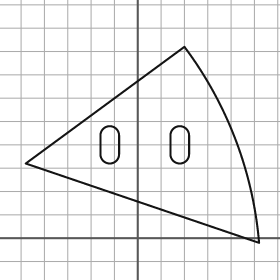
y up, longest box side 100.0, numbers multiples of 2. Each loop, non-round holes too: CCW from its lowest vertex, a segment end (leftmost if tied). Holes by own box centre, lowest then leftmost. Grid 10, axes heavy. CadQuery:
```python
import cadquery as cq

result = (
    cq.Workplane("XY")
    .moveTo(52.0, -2.0)
    .threePointArc((42.0, 42.0), (20.0, 82.0))
    .lineTo(-48.0, 32.0)
    .close()
    .moveTo(-16.0, 36.0)
    .threePointArc((-12.0, 32.0), (-8.0, 36.0))
    .lineTo(-8.0, 44.0)
    .threePointArc((-12.0, 48.0), (-16.0, 44.0))
    .close()
    .moveTo(14.0, 36.0)
    .threePointArc((18.0, 32.0), (22.0, 36.0))
    .lineTo(22.0, 44.0)
    .threePointArc((18.0, 48.0), (14.0, 44.0))
    .close()
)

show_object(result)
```